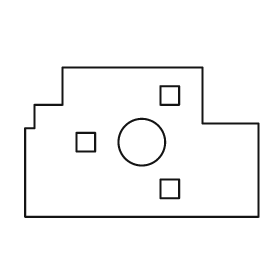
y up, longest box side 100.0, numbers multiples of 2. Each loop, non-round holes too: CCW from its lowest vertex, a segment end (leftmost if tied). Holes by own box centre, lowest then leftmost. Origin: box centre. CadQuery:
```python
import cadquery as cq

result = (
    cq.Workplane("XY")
    .moveTo(-50.0, -32.0)
    .lineTo(50.0, -32.0)
    .lineTo(50.0, 8.0)
    .lineTo(26.0, 8.0)
    .lineTo(26.0, 32.0)
    .lineTo(-34.0, 32.0)
    .lineTo(-34.0, 16.0)
    .lineTo(-46.0, 16.0)
    .lineTo(-46.0, 6.0)
    .lineTo(-50.0, 6.0)
    .close()
    .moveTo(8.0, -24.0)
    .lineTo(16.0, -24.0)
    .lineTo(16.0, -16.0)
    .lineTo(8.0, -16.0)
    .close()
    .moveTo(-28.0, -4.0)
    .lineTo(-20.0, -4.0)
    .lineTo(-20.0, 4.0)
    .lineTo(-28.0, 4.0)
    .close()
    .moveTo(0.0, 0.0)
    .circle(10.0)
    .moveTo(8.0, 16.0)
    .lineTo(16.0, 16.0)
    .lineTo(16.0, 24.0)
    .lineTo(8.0, 24.0)
    .close()
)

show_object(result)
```